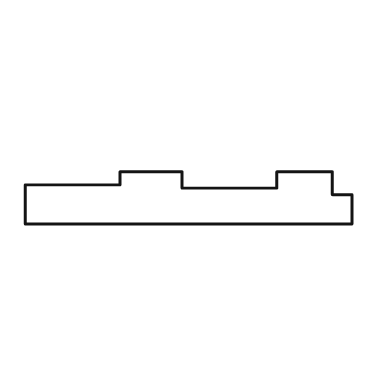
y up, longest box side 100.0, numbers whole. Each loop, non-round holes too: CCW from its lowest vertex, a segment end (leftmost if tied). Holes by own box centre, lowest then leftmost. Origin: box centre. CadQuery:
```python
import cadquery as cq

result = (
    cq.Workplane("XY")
    .moveTo(-50.0, -8.0)
    .lineTo(50.0, -8.0)
    .lineTo(50.0, 1.0)
    .lineTo(44.0, 1.0)
    .lineTo(44.0, 8.0)
    .lineTo(27.0, 8.0)
    .lineTo(27.0, 3.0)
    .lineTo(-2.0, 3.0)
    .lineTo(-2.0, 8.0)
    .lineTo(-21.0, 8.0)
    .lineTo(-21.0, 4.0)
    .lineTo(-50.0, 4.0)
    .close()
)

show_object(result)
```